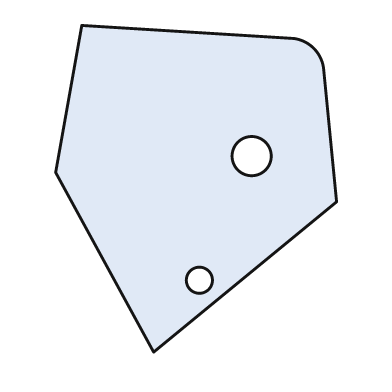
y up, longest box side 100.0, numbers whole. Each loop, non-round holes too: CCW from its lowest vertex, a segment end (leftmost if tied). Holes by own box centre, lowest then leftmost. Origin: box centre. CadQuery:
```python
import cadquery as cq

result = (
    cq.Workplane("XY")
    .moveTo(-13.0, -50.0)
    .lineTo(43.0, -4.0)
    .lineTo(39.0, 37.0)
    .threePointArc((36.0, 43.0), (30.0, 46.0))
    .lineTo(-35.0, 50.0)
    .lineTo(-43.0, 5.0)
    .close()
    .moveTo(1.0, -28.0)
    .circle(4.0)
    .moveTo(17.0, 10.0)
    .circle(6.0)
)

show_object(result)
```